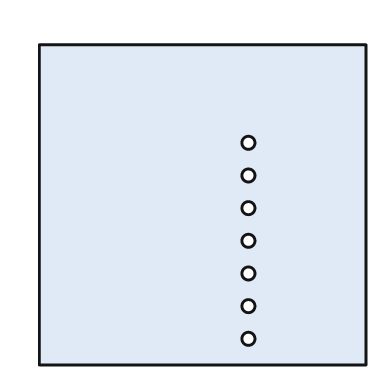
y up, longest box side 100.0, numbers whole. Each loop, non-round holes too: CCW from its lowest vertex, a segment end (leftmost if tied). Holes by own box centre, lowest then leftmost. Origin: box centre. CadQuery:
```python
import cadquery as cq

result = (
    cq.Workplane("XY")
    .moveTo(-50.0, -49.0)
    .lineTo(50.0, -49.0)
    .lineTo(50.0, 49.0)
    .lineTo(-50.0, 49.0)
    .close()
    .moveTo(14.0, -41.0)
    .circle(2.0)
    .moveTo(14.0, -31.0)
    .circle(2.0)
    .moveTo(14.0, -21.0)
    .circle(2.0)
    .moveTo(14.0, -11.0)
    .circle(2.0)
    .moveTo(14.0, -1.0)
    .circle(2.0)
    .moveTo(14.0, 9.0)
    .circle(2.0)
    .moveTo(14.0, 19.0)
    .circle(2.0)
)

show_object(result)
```